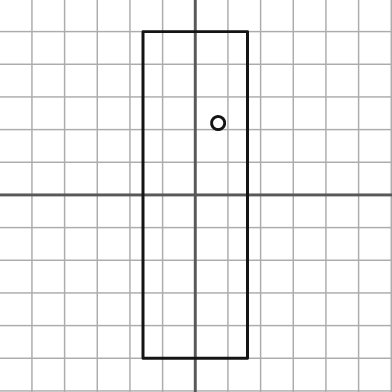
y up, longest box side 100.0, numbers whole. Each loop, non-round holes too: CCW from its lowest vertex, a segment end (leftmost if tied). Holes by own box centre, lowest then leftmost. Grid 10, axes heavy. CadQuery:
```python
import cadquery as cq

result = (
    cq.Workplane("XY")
    .moveTo(-16.0, -50.0)
    .lineTo(16.0, -50.0)
    .lineTo(16.0, 50.0)
    .lineTo(-16.0, 50.0)
    .close()
    .moveTo(7.0, 22.0)
    .circle(2.0)
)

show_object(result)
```